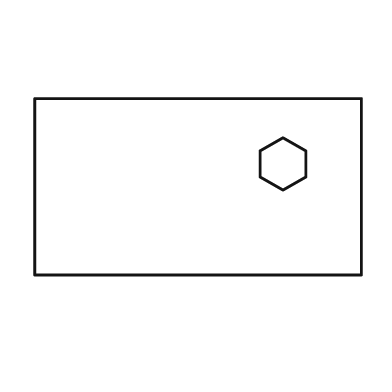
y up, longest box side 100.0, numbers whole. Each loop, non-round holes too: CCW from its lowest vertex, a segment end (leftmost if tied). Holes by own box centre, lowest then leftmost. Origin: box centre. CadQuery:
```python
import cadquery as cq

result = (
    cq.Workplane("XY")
    .moveTo(-50.0, -27.0)
    .lineTo(50.0, -27.0)
    .lineTo(50.0, 27.0)
    .lineTo(-50.0, 27.0)
    .close()
    .moveTo(26.0, -1.0)
    .lineTo(33.0, 3.0)
    .lineTo(33.0, 11.0)
    .lineTo(26.0, 15.0)
    .lineTo(19.0, 11.0)
    .lineTo(19.0, 3.0)
    .close()
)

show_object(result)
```